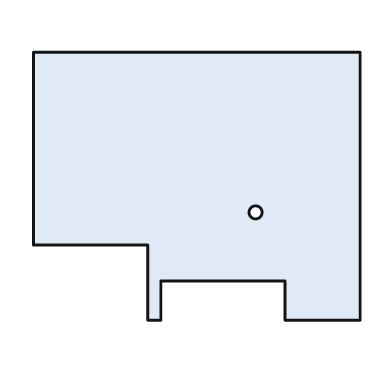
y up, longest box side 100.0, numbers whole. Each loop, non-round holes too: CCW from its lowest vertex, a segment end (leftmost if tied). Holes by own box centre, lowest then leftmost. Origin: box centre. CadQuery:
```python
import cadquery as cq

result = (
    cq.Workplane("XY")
    .moveTo(-15.0, -41.0)
    .lineTo(-11.0, -41.0)
    .lineTo(-11.0, -29.0)
    .lineTo(27.0, -29.0)
    .lineTo(27.0, -41.0)
    .lineTo(50.0, -41.0)
    .lineTo(50.0, 41.0)
    .lineTo(-50.0, 41.0)
    .lineTo(-50.0, -18.0)
    .lineTo(-15.0, -18.0)
    .close()
    .moveTo(18.0, -8.0)
    .circle(2.0)
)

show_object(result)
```